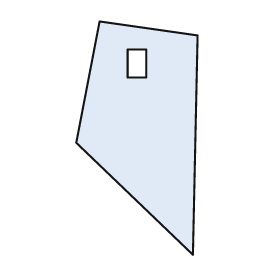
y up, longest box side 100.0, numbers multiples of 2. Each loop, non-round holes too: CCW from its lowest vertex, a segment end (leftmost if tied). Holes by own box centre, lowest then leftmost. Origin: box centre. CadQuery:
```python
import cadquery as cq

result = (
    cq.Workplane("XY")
    .moveTo(24.0, -50.0)
    .lineTo(26.0, 44.0)
    .lineTo(-16.0, 50.0)
    .lineTo(-26.0, -2.0)
    .close()
    .moveTo(-4.0, 26.0)
    .lineTo(4.0, 26.0)
    .lineTo(4.0, 38.0)
    .lineTo(-4.0, 38.0)
    .close()
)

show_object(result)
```